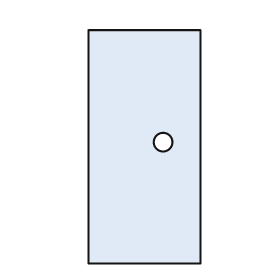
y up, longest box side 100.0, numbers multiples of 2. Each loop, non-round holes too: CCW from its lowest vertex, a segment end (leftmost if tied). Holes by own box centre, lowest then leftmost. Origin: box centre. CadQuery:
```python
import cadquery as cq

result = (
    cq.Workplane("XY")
    .moveTo(-24.0, -50.0)
    .lineTo(24.0, -50.0)
    .lineTo(24.0, 50.0)
    .lineTo(-24.0, 50.0)
    .close()
    .moveTo(8.0, 2.0)
    .circle(4.0)
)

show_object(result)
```